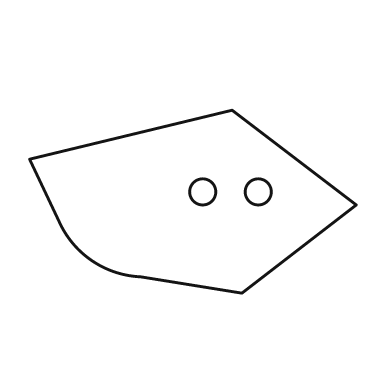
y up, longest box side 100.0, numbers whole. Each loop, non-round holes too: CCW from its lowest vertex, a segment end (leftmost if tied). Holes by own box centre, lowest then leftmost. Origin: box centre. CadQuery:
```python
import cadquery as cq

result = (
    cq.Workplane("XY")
    .moveTo(15.0, -28.0)
    .lineTo(50.0, -1.0)
    .lineTo(12.0, 28.0)
    .lineTo(-50.0, 13.0)
    .lineTo(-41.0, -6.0)
    .threePointArc((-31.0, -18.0), (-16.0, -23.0))
    .close()
    .moveTo(3.0, 3.0)
    .circle(4.0)
    .moveTo(20.0, 3.0)
    .circle(4.0)
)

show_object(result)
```